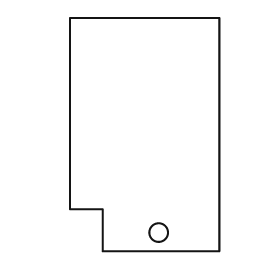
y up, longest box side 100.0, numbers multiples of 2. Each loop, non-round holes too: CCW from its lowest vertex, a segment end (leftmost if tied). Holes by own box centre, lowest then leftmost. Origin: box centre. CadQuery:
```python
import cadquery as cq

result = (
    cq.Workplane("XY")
    .moveTo(-18.0, -50.0)
    .lineTo(32.0, -50.0)
    .lineTo(32.0, 50.0)
    .lineTo(-32.0, 50.0)
    .lineTo(-32.0, -32.0)
    .lineTo(-18.0, -32.0)
    .close()
    .moveTo(6.0, -42.0)
    .circle(4.0)
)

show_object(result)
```